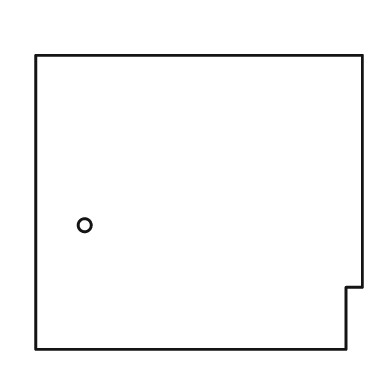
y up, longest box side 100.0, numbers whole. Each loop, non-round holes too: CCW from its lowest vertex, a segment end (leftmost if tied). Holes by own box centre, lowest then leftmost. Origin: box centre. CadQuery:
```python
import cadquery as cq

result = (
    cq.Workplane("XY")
    .moveTo(-50.0, -45.0)
    .lineTo(45.0, -45.0)
    .lineTo(45.0, -26.0)
    .lineTo(50.0, -26.0)
    .lineTo(50.0, 45.0)
    .lineTo(-50.0, 45.0)
    .close()
    .moveTo(-35.0, -7.0)
    .circle(2.0)
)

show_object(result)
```